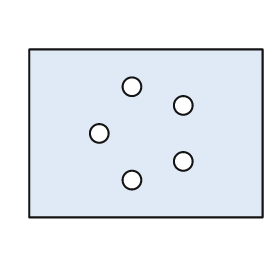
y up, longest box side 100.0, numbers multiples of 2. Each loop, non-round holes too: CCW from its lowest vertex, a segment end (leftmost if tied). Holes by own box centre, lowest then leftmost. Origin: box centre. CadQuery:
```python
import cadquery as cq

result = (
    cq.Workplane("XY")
    .moveTo(-50.0, -36.0)
    .lineTo(50.0, -36.0)
    .lineTo(50.0, 36.0)
    .lineTo(-50.0, 36.0)
    .close()
    .moveTo(-6.0, -20.0)
    .circle(4.0)
    .moveTo(16.0, -12.0)
    .circle(4.0)
    .moveTo(-20.0, 0.0)
    .circle(4.0)
    .moveTo(16.0, 12.0)
    .circle(4.0)
    .moveTo(-6.0, 20.0)
    .circle(4.0)
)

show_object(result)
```